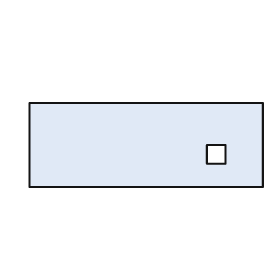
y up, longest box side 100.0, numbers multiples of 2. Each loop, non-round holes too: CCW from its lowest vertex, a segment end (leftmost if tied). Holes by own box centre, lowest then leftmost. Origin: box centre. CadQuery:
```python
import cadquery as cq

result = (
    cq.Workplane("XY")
    .moveTo(-50.0, -18.0)
    .lineTo(50.0, -18.0)
    .lineTo(50.0, 18.0)
    .lineTo(-50.0, 18.0)
    .close()
    .moveTo(26.0, -8.0)
    .lineTo(34.0, -8.0)
    .lineTo(34.0, 0.0)
    .lineTo(26.0, 0.0)
    .close()
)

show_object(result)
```